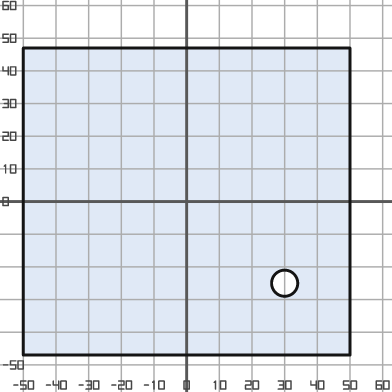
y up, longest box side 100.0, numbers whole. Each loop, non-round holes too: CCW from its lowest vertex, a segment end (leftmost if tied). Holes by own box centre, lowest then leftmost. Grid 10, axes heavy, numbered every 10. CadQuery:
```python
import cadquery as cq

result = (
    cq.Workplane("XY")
    .moveTo(-50.0, -47.0)
    .lineTo(50.0, -47.0)
    .lineTo(50.0, 47.0)
    .lineTo(-50.0, 47.0)
    .close()
    .moveTo(30.0, -25.0)
    .circle(4.0)
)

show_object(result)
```